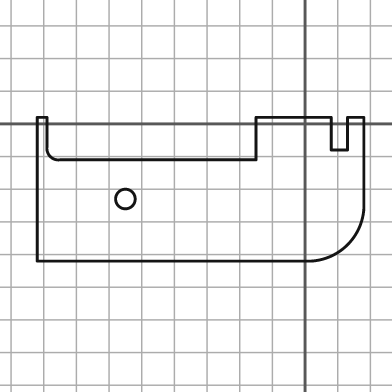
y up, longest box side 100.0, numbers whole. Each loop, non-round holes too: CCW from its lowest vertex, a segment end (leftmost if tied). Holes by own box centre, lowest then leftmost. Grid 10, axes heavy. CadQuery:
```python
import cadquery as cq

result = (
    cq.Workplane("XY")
    .moveTo(-82.0, -42.0)
    .lineTo(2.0, -42.0)
    .threePointArc((13.0, -37.0), (18.0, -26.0))
    .lineTo(18.0, 2.0)
    .lineTo(13.0, 2.0)
    .lineTo(13.0, -8.0)
    .lineTo(8.0, -8.0)
    .lineTo(8.0, 2.0)
    .lineTo(-15.0, 2.0)
    .lineTo(-15.0, -11.0)
    .lineTo(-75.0, -11.0)
    .threePointArc((-78.0, -10.0), (-79.0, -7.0))
    .lineTo(-79.0, 2.0)
    .lineTo(-82.0, 2.0)
    .close()
    .moveTo(-55.0, -23.0)
    .circle(3.0)
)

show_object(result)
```